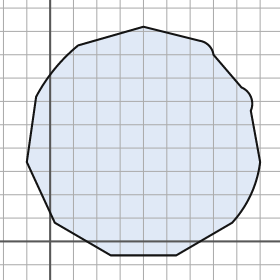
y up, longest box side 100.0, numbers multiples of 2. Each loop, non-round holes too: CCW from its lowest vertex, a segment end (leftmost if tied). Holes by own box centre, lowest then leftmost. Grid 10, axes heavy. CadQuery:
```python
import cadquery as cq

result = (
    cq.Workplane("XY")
    .moveTo(26.0, -6.0)
    .lineTo(54.0, -6.0)
    .lineTo(78.0, 8.0)
    .threePointArc((86.0, 20.0), (90.0, 34.0))
    .lineTo(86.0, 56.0)
    .threePointArc((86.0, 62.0), (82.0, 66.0))
    .lineTo(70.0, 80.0)
    .threePointArc((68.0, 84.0), (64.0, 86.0))
    .lineTo(40.0, 92.0)
    .lineTo(12.0, 84.0)
    .threePointArc((2.0, 74.0), (-6.0, 62.0))
    .lineTo(-10.0, 34.0)
    .lineTo(2.0, 8.0)
    .close()
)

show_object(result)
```